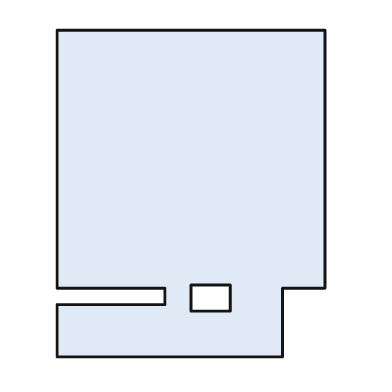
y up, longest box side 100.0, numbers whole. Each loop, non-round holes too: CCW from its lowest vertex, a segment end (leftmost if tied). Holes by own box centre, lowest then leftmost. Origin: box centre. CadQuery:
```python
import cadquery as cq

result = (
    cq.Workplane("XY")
    .moveTo(-41.0, -50.0)
    .lineTo(28.0, -50.0)
    .lineTo(28.0, -29.0)
    .lineTo(41.0, -29.0)
    .lineTo(41.0, 50.0)
    .lineTo(-41.0, 50.0)
    .lineTo(-41.0, -29.0)
    .lineTo(-8.0, -29.0)
    .lineTo(-8.0, -34.0)
    .lineTo(-41.0, -34.0)
    .close()
    .moveTo(0.0, -36.0)
    .lineTo(12.0, -36.0)
    .lineTo(12.0, -28.0)
    .lineTo(0.0, -28.0)
    .close()
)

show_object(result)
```